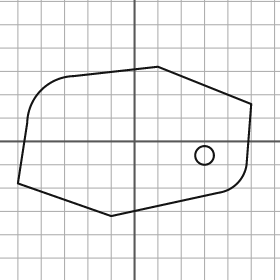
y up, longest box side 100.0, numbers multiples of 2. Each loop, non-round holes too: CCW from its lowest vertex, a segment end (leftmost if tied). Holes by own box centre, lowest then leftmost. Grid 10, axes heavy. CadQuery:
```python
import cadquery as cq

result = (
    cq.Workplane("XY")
    .moveTo(-10.0, -32.0)
    .lineTo(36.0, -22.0)
    .threePointArc((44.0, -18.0), (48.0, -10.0))
    .lineTo(50.0, 16.0)
    .lineTo(10.0, 32.0)
    .lineTo(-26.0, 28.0)
    .threePointArc((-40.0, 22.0), (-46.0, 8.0))
    .lineTo(-50.0, -18.0)
    .close()
    .moveTo(30.0, -6.0)
    .circle(4.0)
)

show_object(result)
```